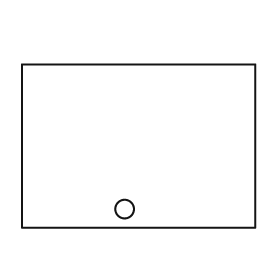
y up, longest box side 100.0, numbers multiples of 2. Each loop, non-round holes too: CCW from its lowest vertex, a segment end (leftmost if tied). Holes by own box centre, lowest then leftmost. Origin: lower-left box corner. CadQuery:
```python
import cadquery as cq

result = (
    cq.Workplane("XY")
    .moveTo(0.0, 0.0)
    .lineTo(100.0, 0.0)
    .lineTo(100.0, 70.0)
    .lineTo(0.0, 70.0)
    .close()
    .moveTo(44.0, 8.0)
    .circle(4.0)
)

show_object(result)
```